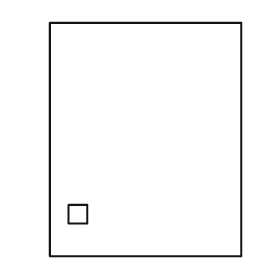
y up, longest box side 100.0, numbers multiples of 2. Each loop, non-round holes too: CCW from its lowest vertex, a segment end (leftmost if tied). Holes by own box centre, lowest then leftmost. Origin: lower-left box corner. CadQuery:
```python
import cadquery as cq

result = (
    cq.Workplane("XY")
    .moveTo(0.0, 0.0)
    .lineTo(82.0, 0.0)
    .lineTo(82.0, 100.0)
    .lineTo(0.0, 100.0)
    .close()
    .moveTo(8.0, 14.0)
    .lineTo(16.0, 14.0)
    .lineTo(16.0, 22.0)
    .lineTo(8.0, 22.0)
    .close()
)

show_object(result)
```